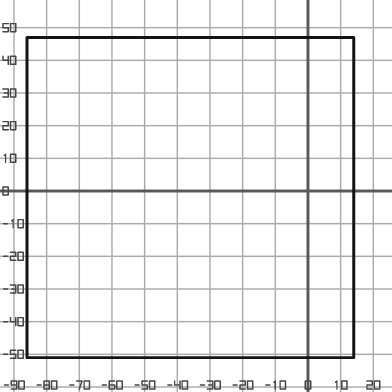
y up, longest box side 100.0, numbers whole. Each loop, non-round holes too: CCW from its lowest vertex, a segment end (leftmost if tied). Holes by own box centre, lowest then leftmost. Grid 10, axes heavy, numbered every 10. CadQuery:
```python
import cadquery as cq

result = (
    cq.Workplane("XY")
    .moveTo(-86.0, -51.0)
    .lineTo(14.0, -51.0)
    .lineTo(14.0, 47.0)
    .lineTo(-86.0, 47.0)
    .close()
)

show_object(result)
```